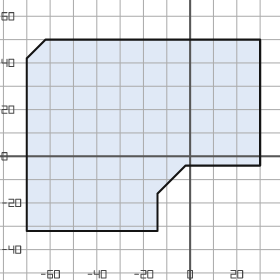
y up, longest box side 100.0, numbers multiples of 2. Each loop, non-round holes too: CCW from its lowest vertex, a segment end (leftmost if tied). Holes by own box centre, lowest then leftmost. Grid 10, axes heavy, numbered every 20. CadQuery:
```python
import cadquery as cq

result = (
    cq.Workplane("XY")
    .moveTo(-70.0, -32.0)
    .lineTo(-14.0, -32.0)
    .lineTo(-14.0, -16.0)
    .lineTo(-2.0, -4.0)
    .lineTo(30.0, -4.0)
    .lineTo(30.0, 50.0)
    .lineTo(-62.0, 50.0)
    .lineTo(-70.0, 42.0)
    .close()
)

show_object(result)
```